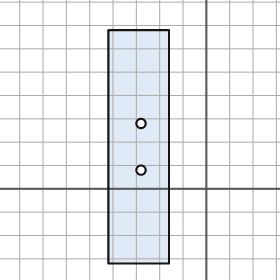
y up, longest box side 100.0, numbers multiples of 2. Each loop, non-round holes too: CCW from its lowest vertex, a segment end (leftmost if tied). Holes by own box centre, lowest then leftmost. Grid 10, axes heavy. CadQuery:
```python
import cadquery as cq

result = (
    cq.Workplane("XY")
    .moveTo(-42.0, -32.0)
    .lineTo(-16.0, -32.0)
    .lineTo(-16.0, 68.0)
    .lineTo(-42.0, 68.0)
    .close()
    .moveTo(-28.0, 8.0)
    .circle(2.0)
    .moveTo(-28.0, 28.0)
    .circle(2.0)
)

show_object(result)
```